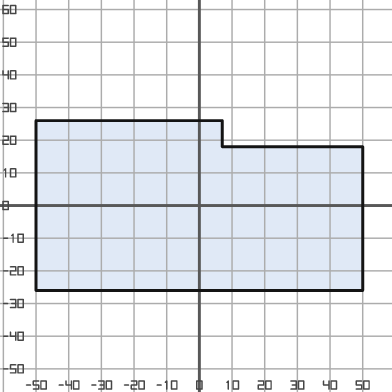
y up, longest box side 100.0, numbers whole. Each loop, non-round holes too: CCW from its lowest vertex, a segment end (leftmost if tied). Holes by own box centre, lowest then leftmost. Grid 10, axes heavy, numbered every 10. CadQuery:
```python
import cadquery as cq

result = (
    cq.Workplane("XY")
    .moveTo(-50.0, -26.0)
    .lineTo(50.0, -26.0)
    .lineTo(50.0, 18.0)
    .lineTo(7.0, 18.0)
    .lineTo(7.0, 26.0)
    .lineTo(-50.0, 26.0)
    .close()
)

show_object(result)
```